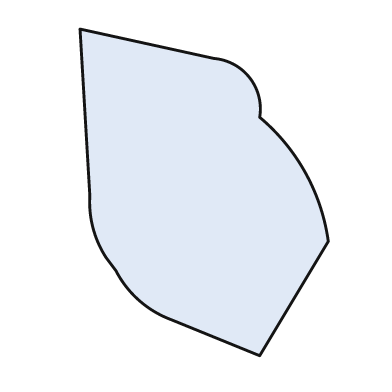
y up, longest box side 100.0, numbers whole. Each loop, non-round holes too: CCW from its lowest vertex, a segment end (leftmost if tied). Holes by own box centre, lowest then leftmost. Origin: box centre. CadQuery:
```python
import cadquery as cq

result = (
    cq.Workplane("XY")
    .moveTo(17.0, -50.0)
    .lineTo(38.0, -15.0)
    .threePointArc((31.0, 6.0), (17.0, 23.0))
    .threePointArc((14.0, 35.0), (3.0, 41.0))
    .lineTo(-38.0, 50.0)
    .lineTo(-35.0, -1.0)
    .threePointArc((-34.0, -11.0), (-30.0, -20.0))
    .lineTo(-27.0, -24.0)
    .threePointArc((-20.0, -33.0), (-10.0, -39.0))
    .close()
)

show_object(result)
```